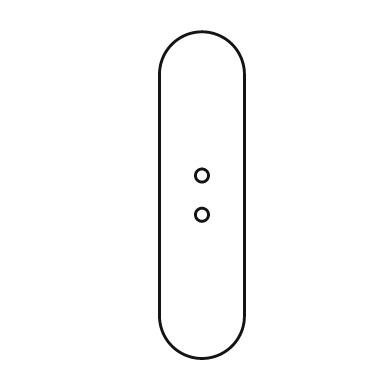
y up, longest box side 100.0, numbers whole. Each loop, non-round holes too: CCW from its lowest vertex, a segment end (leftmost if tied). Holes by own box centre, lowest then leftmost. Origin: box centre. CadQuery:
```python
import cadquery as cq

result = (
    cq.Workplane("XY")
    .moveTo(-13.0, -37.0)
    .threePointArc((0.0, -50.0), (13.0, -37.0))
    .lineTo(13.0, 37.0)
    .threePointArc((0.0, 50.0), (-13.0, 37.0))
    .close()
    .moveTo(0.0, -6.0)
    .circle(2.0)
    .moveTo(0.0, 6.0)
    .circle(2.0)
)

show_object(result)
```